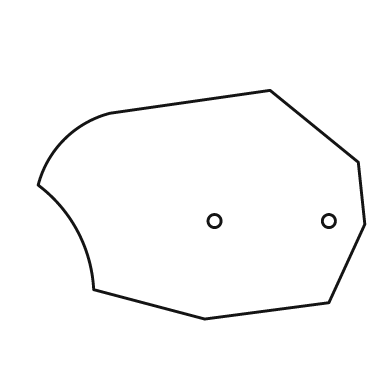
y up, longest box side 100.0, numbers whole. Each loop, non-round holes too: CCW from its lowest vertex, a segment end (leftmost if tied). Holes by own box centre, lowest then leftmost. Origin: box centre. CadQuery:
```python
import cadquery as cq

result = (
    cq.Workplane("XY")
    .moveTo(1.0, -35.0)
    .lineTo(39.0, -30.0)
    .lineTo(50.0, -6.0)
    .lineTo(48.0, 13.0)
    .lineTo(21.0, 35.0)
    .lineTo(-28.0, 28.0)
    .threePointArc((-42.0, 20.0), (-50.0, 6.0))
    .threePointArc((-38.0, -8.0), (-33.0, -26.0))
    .close()
    .moveTo(4.0, -5.0)
    .circle(2.0)
    .moveTo(39.0, -5.0)
    .circle(2.0)
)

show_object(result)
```